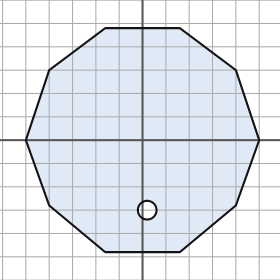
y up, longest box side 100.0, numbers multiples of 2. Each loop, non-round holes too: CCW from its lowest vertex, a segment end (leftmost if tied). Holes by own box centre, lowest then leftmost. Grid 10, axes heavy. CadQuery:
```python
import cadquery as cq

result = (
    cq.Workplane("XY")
    .moveTo(-16.0, -48.0)
    .lineTo(16.0, -48.0)
    .lineTo(40.0, -28.0)
    .lineTo(50.0, 0.0)
    .lineTo(40.0, 30.0)
    .lineTo(16.0, 48.0)
    .lineTo(-16.0, 48.0)
    .lineTo(-40.0, 30.0)
    .lineTo(-50.0, 0.0)
    .lineTo(-40.0, -28.0)
    .close()
    .moveTo(2.0, -30.0)
    .circle(4.0)
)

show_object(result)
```